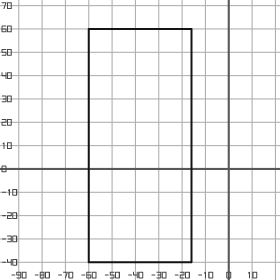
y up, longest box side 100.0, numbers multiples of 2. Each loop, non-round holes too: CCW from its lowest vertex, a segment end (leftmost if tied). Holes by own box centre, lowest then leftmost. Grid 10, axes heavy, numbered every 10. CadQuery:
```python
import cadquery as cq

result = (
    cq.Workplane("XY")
    .moveTo(-60.0, -40.0)
    .lineTo(-16.0, -40.0)
    .lineTo(-16.0, 60.0)
    .lineTo(-60.0, 60.0)
    .close()
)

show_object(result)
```